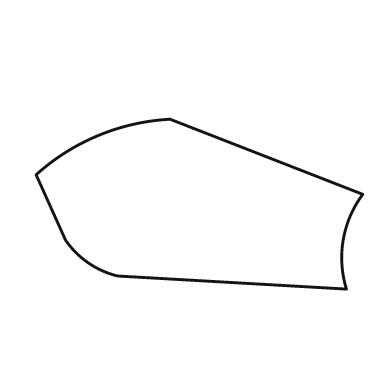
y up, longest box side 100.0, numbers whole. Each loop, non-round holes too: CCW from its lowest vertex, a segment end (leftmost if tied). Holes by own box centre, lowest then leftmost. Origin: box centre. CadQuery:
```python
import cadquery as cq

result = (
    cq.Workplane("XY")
    .moveTo(45.0, -26.0)
    .threePointArc((44.0, -11.0), (50.0, 3.0))
    .lineTo(-9.0, 26.0)
    .threePointArc((-31.0, 21.0), (-50.0, 9.0))
    .lineTo(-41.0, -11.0)
    .threePointArc((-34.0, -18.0), (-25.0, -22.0))
    .close()
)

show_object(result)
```